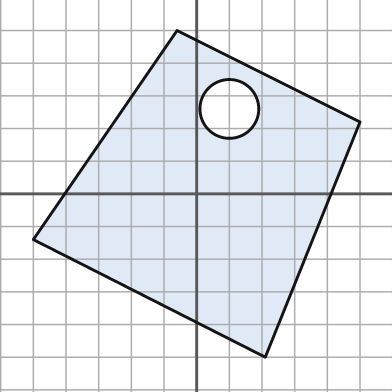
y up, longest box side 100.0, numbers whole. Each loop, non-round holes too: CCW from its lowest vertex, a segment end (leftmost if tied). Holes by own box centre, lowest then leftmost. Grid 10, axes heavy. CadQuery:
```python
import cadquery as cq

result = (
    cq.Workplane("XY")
    .moveTo(21.0, -50.0)
    .lineTo(50.0, 22.0)
    .lineTo(-6.0, 50.0)
    .lineTo(-50.0, -14.0)
    .close()
    .moveTo(10.0, 26.0)
    .circle(9.0)
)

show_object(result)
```